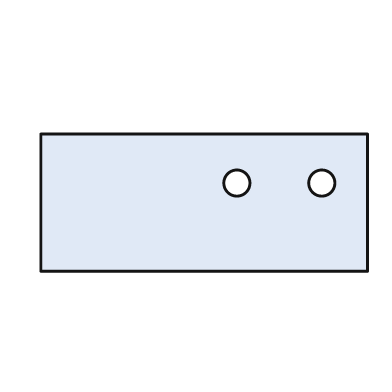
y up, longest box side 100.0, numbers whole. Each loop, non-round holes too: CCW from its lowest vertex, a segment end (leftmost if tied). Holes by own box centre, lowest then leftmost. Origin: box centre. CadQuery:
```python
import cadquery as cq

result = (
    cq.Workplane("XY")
    .moveTo(-50.0, -21.0)
    .lineTo(50.0, -21.0)
    .lineTo(50.0, 21.0)
    .lineTo(-50.0, 21.0)
    .close()
    .moveTo(10.0, 6.0)
    .circle(4.0)
    .moveTo(36.0, 6.0)
    .circle(4.0)
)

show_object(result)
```